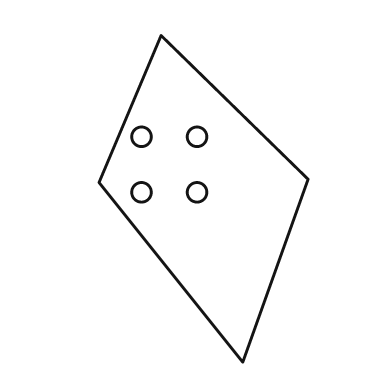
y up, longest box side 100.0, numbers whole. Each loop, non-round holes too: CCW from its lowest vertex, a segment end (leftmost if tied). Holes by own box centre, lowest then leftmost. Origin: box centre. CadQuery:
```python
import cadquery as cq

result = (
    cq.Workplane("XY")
    .moveTo(12.0, -50.0)
    .lineTo(32.0, 6.0)
    .lineTo(-13.0, 50.0)
    .lineTo(-32.0, 5.0)
    .close()
    .moveTo(-19.0, 2.0)
    .circle(3.0)
    .moveTo(-2.0, 2.0)
    .circle(3.0)
    .moveTo(-19.0, 19.0)
    .circle(3.0)
    .moveTo(-2.0, 19.0)
    .circle(3.0)
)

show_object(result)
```